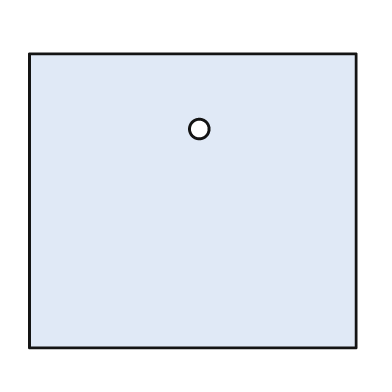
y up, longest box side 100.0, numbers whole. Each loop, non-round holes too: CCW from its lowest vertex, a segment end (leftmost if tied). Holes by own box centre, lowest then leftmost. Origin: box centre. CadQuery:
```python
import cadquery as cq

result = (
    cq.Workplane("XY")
    .moveTo(-50.0, -45.0)
    .lineTo(50.0, -45.0)
    .lineTo(50.0, 45.0)
    .lineTo(-50.0, 45.0)
    .close()
    .moveTo(2.0, 22.0)
    .circle(3.0)
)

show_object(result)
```